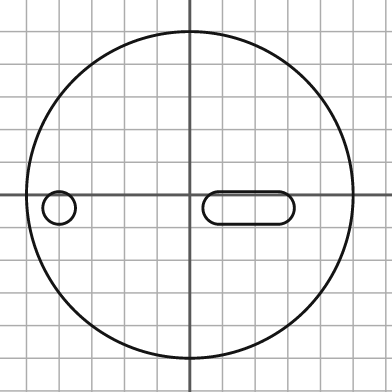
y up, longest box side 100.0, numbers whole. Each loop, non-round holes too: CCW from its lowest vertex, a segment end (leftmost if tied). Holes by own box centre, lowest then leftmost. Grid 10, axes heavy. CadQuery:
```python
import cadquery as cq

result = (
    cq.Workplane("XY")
    .moveTo(0.0, 0.0)
    .circle(50.0)
    .moveTo(-40.0, -4.0)
    .circle(5.0)
    .moveTo(9.0, -9.0)
    .lineTo(27.0, -9.0)
    .threePointArc((32.0, -4.0), (27.0, 1.0))
    .lineTo(9.0, 1.0)
    .threePointArc((4.0, -4.0), (9.0, -9.0))
    .close()
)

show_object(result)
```